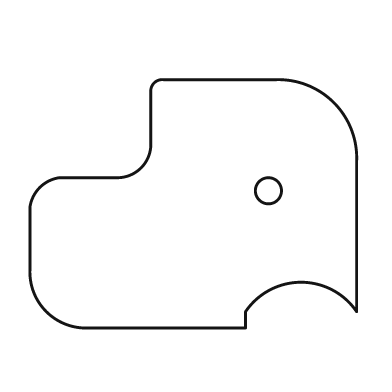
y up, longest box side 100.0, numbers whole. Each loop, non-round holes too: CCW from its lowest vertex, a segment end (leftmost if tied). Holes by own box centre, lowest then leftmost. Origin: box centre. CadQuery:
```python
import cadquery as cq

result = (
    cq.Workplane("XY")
    .moveTo(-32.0, -38.0)
    .lineTo(16.0, -38.0)
    .lineTo(16.0, -33.0)
    .threePointArc((33.0, -24.0), (50.0, -33.0))
    .lineTo(50.0, 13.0)
    .threePointArc((43.0, 31.0), (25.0, 38.0))
    .lineTo(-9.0, 38.0)
    .threePointArc((-12.0, 37.0), (-13.0, 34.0))
    .lineTo(-13.0, 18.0)
    .threePointArc((-16.0, 11.0), (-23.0, 8.0))
    .lineTo(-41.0, 8.0)
    .threePointArc((-47.0, 5.0), (-50.0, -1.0))
    .lineTo(-50.0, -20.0)
    .threePointArc((-45.0, -33.0), (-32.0, -38.0))
    .close()
    .moveTo(23.0, 4.0)
    .circle(4.0)
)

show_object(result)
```